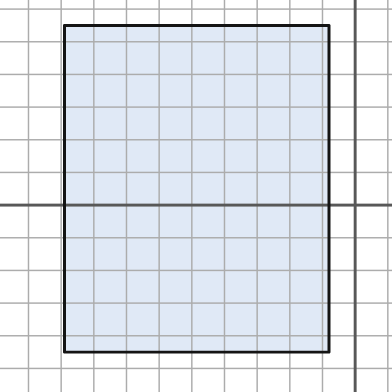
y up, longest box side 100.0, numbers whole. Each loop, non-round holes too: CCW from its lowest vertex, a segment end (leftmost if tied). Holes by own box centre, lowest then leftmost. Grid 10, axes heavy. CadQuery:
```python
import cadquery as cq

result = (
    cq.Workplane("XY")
    .moveTo(-89.0, -45.0)
    .lineTo(-8.0, -45.0)
    .lineTo(-8.0, 55.0)
    .lineTo(-89.0, 55.0)
    .close()
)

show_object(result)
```